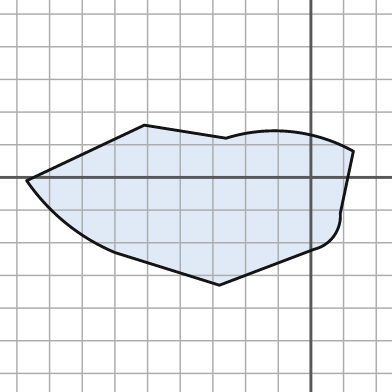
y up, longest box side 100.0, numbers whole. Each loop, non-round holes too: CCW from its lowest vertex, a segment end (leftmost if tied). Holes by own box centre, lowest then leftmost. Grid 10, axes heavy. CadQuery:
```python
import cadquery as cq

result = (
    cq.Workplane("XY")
    .moveTo(-28.0, -33.0)
    .lineTo(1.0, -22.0)
    .threePointArc((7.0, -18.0), (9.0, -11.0))
    .lineTo(13.0, 8.0)
    .threePointArc((-6.0, 14.0), (-26.0, 12.0))
    .lineTo(-51.0, 16.0)
    .lineTo(-87.0, -1.0)
    .threePointArc((-75.0, -14.0), (-60.0, -23.0))
    .close()
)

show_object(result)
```